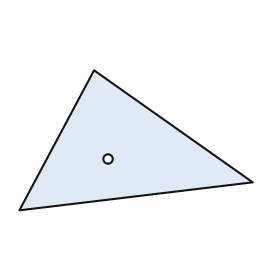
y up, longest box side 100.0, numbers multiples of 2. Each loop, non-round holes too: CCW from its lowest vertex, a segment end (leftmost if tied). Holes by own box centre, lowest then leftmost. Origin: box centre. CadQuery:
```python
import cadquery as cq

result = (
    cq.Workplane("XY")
    .moveTo(-50.0, -30.0)
    .lineTo(50.0, -18.0)
    .lineTo(-18.0, 30.0)
    .close()
    .moveTo(-12.0, -8.0)
    .circle(2.0)
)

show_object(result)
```